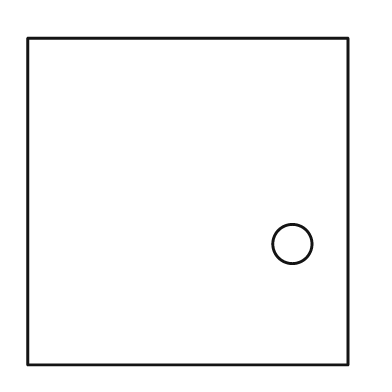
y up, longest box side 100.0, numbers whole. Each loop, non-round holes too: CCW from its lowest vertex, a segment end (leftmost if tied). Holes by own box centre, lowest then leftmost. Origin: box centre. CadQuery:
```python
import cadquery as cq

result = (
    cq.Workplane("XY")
    .moveTo(-49.0, -50.0)
    .lineTo(49.0, -50.0)
    .lineTo(49.0, 50.0)
    .lineTo(-49.0, 50.0)
    .close()
    .moveTo(32.0, -13.0)
    .circle(6.0)
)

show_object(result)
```